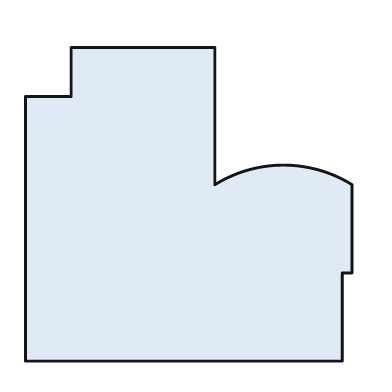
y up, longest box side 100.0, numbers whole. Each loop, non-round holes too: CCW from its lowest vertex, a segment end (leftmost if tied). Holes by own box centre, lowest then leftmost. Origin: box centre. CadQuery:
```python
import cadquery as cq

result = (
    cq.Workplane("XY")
    .moveTo(-50.0, -48.0)
    .lineTo(47.0, -48.0)
    .lineTo(47.0, -21.0)
    .lineTo(50.0, -21.0)
    .lineTo(50.0, 6.0)
    .threePointArc((29.0, 12.0), (8.0, 6.0))
    .lineTo(8.0, 48.0)
    .lineTo(-36.0, 48.0)
    .lineTo(-36.0, 33.0)
    .lineTo(-50.0, 33.0)
    .close()
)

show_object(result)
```